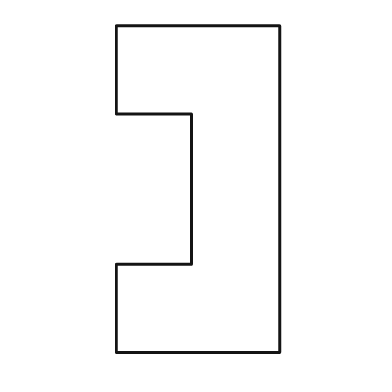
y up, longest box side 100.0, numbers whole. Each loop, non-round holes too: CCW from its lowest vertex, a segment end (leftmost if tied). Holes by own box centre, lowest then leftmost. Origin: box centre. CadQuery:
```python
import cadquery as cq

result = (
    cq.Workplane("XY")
    .moveTo(-25.0, -50.0)
    .lineTo(25.0, -50.0)
    .lineTo(25.0, 50.0)
    .lineTo(-25.0, 50.0)
    .lineTo(-25.0, 23.0)
    .lineTo(-2.0, 23.0)
    .lineTo(-2.0, -23.0)
    .lineTo(-25.0, -23.0)
    .close()
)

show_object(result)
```